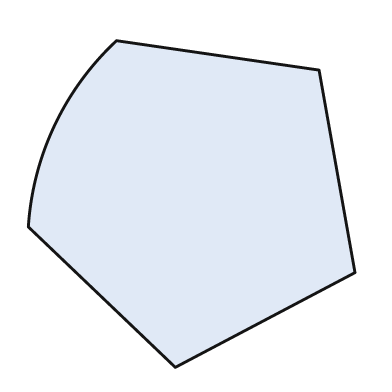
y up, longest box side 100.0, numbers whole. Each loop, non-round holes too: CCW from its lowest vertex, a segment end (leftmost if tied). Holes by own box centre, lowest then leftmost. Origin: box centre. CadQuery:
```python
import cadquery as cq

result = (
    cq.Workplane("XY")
    .moveTo(-5.0, -50.0)
    .lineTo(50.0, -21.0)
    .lineTo(39.0, 41.0)
    .lineTo(-23.0, 50.0)
    .threePointArc((-42.0, 24.0), (-50.0, -7.0))
    .close()
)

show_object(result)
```